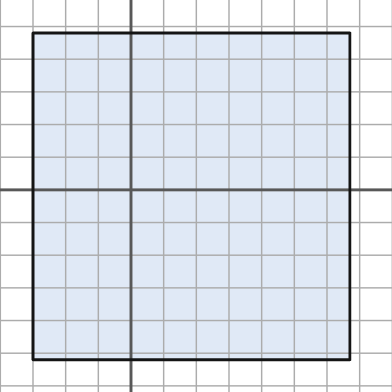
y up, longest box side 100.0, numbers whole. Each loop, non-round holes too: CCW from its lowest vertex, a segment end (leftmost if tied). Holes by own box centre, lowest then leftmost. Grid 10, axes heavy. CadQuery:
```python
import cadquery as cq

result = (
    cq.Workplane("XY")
    .moveTo(-30.0, -52.0)
    .lineTo(67.0, -52.0)
    .lineTo(67.0, 48.0)
    .lineTo(-30.0, 48.0)
    .close()
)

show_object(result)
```